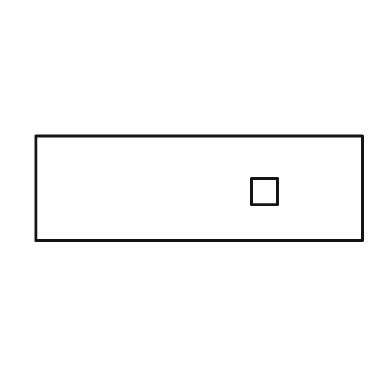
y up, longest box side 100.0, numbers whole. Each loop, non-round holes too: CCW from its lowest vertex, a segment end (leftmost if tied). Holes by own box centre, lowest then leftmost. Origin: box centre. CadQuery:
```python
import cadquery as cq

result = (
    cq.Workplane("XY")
    .moveTo(-50.0, -16.0)
    .lineTo(50.0, -16.0)
    .lineTo(50.0, 16.0)
    .lineTo(-50.0, 16.0)
    .close()
    .moveTo(16.0, -5.0)
    .lineTo(24.0, -5.0)
    .lineTo(24.0, 3.0)
    .lineTo(16.0, 3.0)
    .close()
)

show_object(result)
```